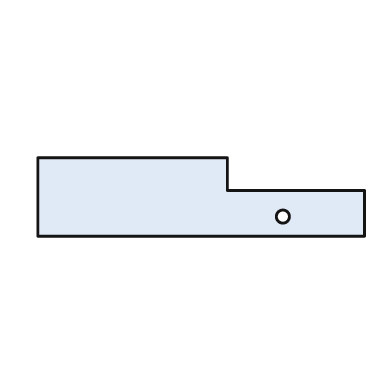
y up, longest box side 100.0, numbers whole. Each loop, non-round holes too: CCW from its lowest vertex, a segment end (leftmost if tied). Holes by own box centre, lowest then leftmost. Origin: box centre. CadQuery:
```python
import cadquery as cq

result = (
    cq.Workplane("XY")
    .moveTo(-50.0, -12.0)
    .lineTo(50.0, -12.0)
    .lineTo(50.0, 2.0)
    .lineTo(8.0, 2.0)
    .lineTo(8.0, 12.0)
    .lineTo(-50.0, 12.0)
    .close()
    .moveTo(25.0, -6.0)
    .circle(2.0)
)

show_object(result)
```